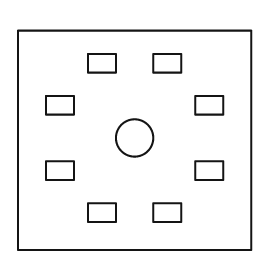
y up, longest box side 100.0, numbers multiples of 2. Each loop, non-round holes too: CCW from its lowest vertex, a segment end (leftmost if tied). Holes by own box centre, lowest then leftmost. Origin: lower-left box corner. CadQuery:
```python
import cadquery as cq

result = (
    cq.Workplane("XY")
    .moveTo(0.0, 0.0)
    .lineTo(100.0, 0.0)
    .lineTo(100.0, 94.0)
    .lineTo(0.0, 94.0)
    .close()
    .moveTo(30.0, 12.0)
    .lineTo(42.0, 12.0)
    .lineTo(42.0, 20.0)
    .lineTo(30.0, 20.0)
    .close()
    .moveTo(58.0, 12.0)
    .lineTo(70.0, 12.0)
    .lineTo(70.0, 20.0)
    .lineTo(58.0, 20.0)
    .close()
    .moveTo(12.0, 30.0)
    .lineTo(24.0, 30.0)
    .lineTo(24.0, 38.0)
    .lineTo(12.0, 38.0)
    .close()
    .moveTo(76.0, 30.0)
    .lineTo(88.0, 30.0)
    .lineTo(88.0, 38.0)
    .lineTo(76.0, 38.0)
    .close()
    .moveTo(50.0, 48.0)
    .circle(8.0)
    .moveTo(12.0, 58.0)
    .lineTo(24.0, 58.0)
    .lineTo(24.0, 66.0)
    .lineTo(12.0, 66.0)
    .close()
    .moveTo(76.0, 58.0)
    .lineTo(88.0, 58.0)
    .lineTo(88.0, 66.0)
    .lineTo(76.0, 66.0)
    .close()
    .moveTo(30.0, 76.0)
    .lineTo(42.0, 76.0)
    .lineTo(42.0, 84.0)
    .lineTo(30.0, 84.0)
    .close()
    .moveTo(58.0, 76.0)
    .lineTo(70.0, 76.0)
    .lineTo(70.0, 84.0)
    .lineTo(58.0, 84.0)
    .close()
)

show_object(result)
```